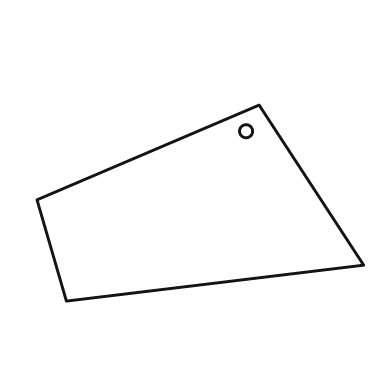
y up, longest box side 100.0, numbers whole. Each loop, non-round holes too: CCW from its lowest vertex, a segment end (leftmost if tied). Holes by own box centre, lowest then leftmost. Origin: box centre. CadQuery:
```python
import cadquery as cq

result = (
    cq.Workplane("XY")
    .moveTo(-41.0, -30.0)
    .lineTo(50.0, -19.0)
    .lineTo(18.0, 30.0)
    .lineTo(-50.0, 1.0)
    .close()
    .moveTo(14.0, 22.0)
    .circle(2.0)
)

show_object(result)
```